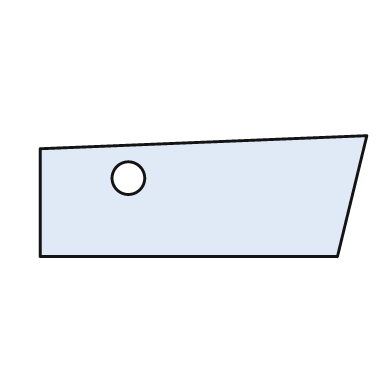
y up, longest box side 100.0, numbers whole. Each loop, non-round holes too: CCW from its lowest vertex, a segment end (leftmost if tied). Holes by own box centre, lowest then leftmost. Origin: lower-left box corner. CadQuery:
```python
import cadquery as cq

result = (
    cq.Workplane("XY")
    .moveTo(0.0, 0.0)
    .lineTo(91.0, 0.0)
    .lineTo(100.0, 37.0)
    .lineTo(0.0, 33.0)
    .close()
    .moveTo(27.0, 24.0)
    .circle(5.0)
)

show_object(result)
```